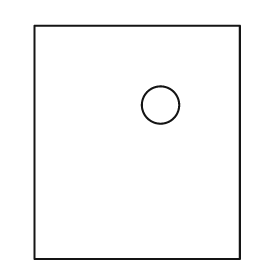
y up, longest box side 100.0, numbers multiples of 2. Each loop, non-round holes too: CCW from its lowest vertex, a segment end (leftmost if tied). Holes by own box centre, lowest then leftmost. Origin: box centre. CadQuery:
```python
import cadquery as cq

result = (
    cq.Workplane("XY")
    .moveTo(-44.0, -50.0)
    .lineTo(44.0, -50.0)
    .lineTo(44.0, 50.0)
    .lineTo(-44.0, 50.0)
    .close()
    .moveTo(10.0, 16.0)
    .circle(8.0)
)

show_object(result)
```